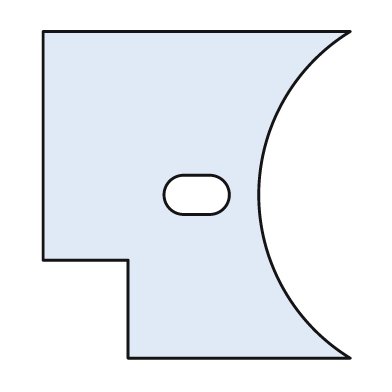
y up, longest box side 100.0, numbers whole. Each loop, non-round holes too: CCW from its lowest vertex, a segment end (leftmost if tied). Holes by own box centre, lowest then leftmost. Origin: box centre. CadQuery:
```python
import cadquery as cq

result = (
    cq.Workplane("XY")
    .moveTo(-21.0, -50.0)
    .lineTo(47.0, -50.0)
    .threePointArc((19.0, 0.0), (47.0, 50.0))
    .lineTo(-47.0, 50.0)
    .lineTo(-47.0, -20.0)
    .lineTo(-21.0, -20.0)
    .close()
    .moveTo(-4.0, -6.0)
    .lineTo(4.0, -6.0)
    .threePointArc((10.0, 0.0), (4.0, 6.0))
    .lineTo(-4.0, 6.0)
    .threePointArc((-10.0, 0.0), (-4.0, -6.0))
    .close()
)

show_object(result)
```